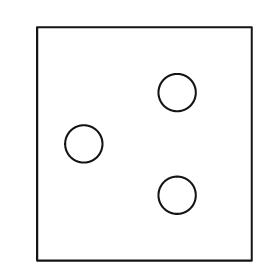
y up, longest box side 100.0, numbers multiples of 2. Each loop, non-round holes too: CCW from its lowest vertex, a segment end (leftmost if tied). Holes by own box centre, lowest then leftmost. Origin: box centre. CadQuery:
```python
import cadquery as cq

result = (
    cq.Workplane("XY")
    .moveTo(-46.0, -50.0)
    .lineTo(46.0, -50.0)
    .lineTo(46.0, 50.0)
    .lineTo(-46.0, 50.0)
    .close()
    .moveTo(14.0, -22.0)
    .circle(8.0)
    .moveTo(-26.0, 0.0)
    .circle(8.0)
    .moveTo(14.0, 22.0)
    .circle(8.0)
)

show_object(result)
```